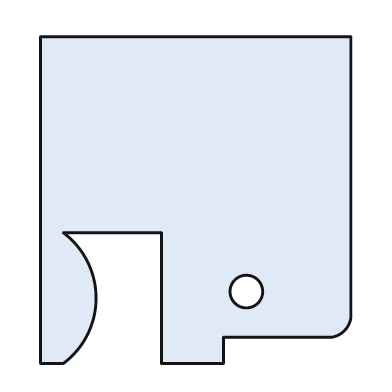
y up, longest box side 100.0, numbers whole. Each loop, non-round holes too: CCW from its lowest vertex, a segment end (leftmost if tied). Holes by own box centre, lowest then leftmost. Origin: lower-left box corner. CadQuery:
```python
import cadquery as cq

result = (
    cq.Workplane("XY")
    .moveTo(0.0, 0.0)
    .lineTo(7.0, 0.0)
    .threePointArc((17.0, 20.0), (7.0, 40.0))
    .lineTo(37.0, 40.0)
    .lineTo(37.0, 0.0)
    .lineTo(56.0, 0.0)
    .lineTo(56.0, 8.0)
    .lineTo(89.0, 8.0)
    .threePointArc((93.0, 10.0), (95.0, 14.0))
    .lineTo(95.0, 100.0)
    .lineTo(0.0, 100.0)
    .close()
    .moveTo(63.0, 22.0)
    .circle(5.0)
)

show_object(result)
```